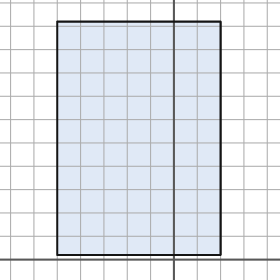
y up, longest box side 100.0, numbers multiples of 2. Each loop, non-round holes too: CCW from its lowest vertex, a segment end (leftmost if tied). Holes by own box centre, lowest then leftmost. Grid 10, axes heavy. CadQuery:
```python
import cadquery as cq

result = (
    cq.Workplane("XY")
    .moveTo(-50.0, 2.0)
    .lineTo(20.0, 2.0)
    .lineTo(20.0, 102.0)
    .lineTo(-50.0, 102.0)
    .close()
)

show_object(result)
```